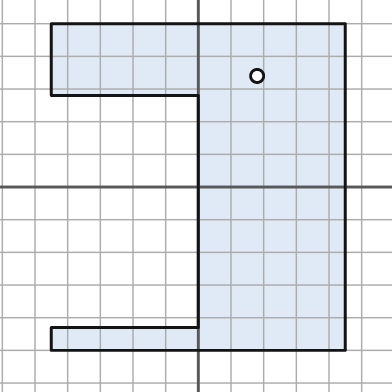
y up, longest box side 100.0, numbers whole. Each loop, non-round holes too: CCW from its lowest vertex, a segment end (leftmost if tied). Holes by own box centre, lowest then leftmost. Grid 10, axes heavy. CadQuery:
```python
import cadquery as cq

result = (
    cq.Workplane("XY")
    .moveTo(-45.0, -50.0)
    .lineTo(45.0, -50.0)
    .lineTo(45.0, 50.0)
    .lineTo(-45.0, 50.0)
    .lineTo(-45.0, 28.0)
    .lineTo(0.0, 28.0)
    .lineTo(0.0, -43.0)
    .lineTo(-45.0, -43.0)
    .close()
    .moveTo(18.0, 34.0)
    .circle(2.0)
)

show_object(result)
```